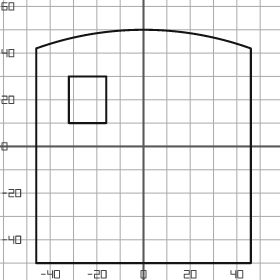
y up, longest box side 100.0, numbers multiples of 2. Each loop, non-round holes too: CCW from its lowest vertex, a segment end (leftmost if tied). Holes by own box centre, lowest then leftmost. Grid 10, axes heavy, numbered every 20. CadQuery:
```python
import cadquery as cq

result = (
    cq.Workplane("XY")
    .moveTo(-46.0, -50.0)
    .lineTo(46.0, -50.0)
    .lineTo(46.0, 42.0)
    .threePointArc((0.0, 50.0), (-46.0, 42.0))
    .close()
    .moveTo(-32.0, 10.0)
    .lineTo(-16.0, 10.0)
    .lineTo(-16.0, 30.0)
    .lineTo(-32.0, 30.0)
    .close()
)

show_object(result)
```